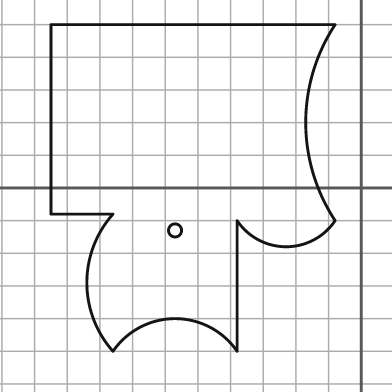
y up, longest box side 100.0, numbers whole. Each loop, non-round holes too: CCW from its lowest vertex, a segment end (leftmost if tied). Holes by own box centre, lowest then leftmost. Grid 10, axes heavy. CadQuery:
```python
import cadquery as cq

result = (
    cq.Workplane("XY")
    .moveTo(-76.0, -50.0)
    .threePointArc((-57.0, -40.0), (-38.0, -50.0))
    .lineTo(-38.0, -10.0)
    .threePointArc((-23.0, -18.0), (-8.0, -10.0))
    .threePointArc((-17.0, 20.0), (-8.0, 50.0))
    .lineTo(-95.0, 50.0)
    .lineTo(-95.0, -8.0)
    .lineTo(-76.0, -8.0)
    .threePointArc((-84.0, -29.0), (-76.0, -50.0))
    .close()
    .moveTo(-57.0, -13.0)
    .circle(2.0)
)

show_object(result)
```